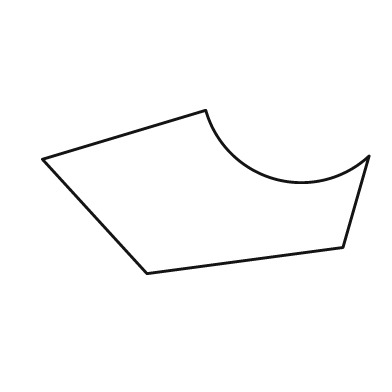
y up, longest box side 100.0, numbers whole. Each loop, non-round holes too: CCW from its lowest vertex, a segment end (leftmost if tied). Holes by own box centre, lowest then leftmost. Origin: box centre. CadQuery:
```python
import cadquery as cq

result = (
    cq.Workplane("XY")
    .moveTo(-18.0, -25.0)
    .lineTo(42.0, -17.0)
    .lineTo(50.0, 11.0)
    .threePointArc((21.0, 4.0), (0.0, 25.0))
    .lineTo(-50.0, 10.0)
    .close()
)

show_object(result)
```